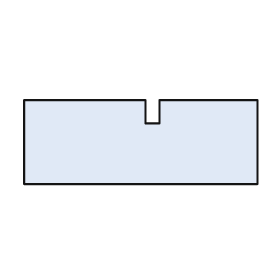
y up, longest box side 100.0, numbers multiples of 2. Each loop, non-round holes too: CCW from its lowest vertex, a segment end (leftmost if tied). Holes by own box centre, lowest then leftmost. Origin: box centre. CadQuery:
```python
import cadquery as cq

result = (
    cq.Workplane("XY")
    .moveTo(-50.0, -18.0)
    .lineTo(50.0, -18.0)
    .lineTo(50.0, 18.0)
    .lineTo(8.0, 18.0)
    .lineTo(8.0, 8.0)
    .lineTo(2.0, 8.0)
    .lineTo(2.0, 18.0)
    .lineTo(-50.0, 18.0)
    .close()
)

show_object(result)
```